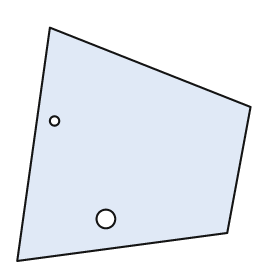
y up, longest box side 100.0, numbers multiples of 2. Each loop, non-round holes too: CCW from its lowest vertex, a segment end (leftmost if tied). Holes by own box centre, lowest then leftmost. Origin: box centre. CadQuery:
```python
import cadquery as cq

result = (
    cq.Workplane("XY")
    .moveTo(-50.0, -50.0)
    .lineTo(40.0, -38.0)
    .lineTo(50.0, 16.0)
    .lineTo(-36.0, 50.0)
    .close()
    .moveTo(-12.0, -32.0)
    .circle(4.0)
    .moveTo(-34.0, 10.0)
    .circle(2.0)
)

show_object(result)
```